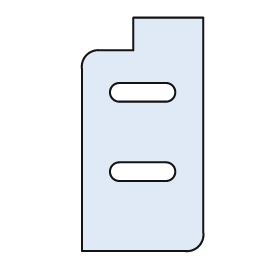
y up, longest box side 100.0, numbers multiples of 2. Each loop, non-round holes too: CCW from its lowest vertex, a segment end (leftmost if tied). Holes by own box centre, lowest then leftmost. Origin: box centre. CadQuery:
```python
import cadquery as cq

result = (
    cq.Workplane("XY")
    .moveTo(-26.0, -50.0)
    .lineTo(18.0, -50.0)
    .threePointArc((24.0, -48.0), (26.0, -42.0))
    .lineTo(26.0, 50.0)
    .lineTo(-4.0, 50.0)
    .lineTo(-4.0, 36.0)
    .lineTo(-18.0, 36.0)
    .threePointArc((-24.0, 34.0), (-26.0, 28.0))
    .close()
    .moveTo(-10.0, -20.0)
    .lineTo(10.0, -20.0)
    .threePointArc((14.0, -16.0), (10.0, -12.0))
    .lineTo(-10.0, -12.0)
    .threePointArc((-14.0, -16.0), (-10.0, -20.0))
    .close()
    .moveTo(-10.0, 14.0)
    .lineTo(10.0, 14.0)
    .threePointArc((14.0, 18.0), (10.0, 22.0))
    .lineTo(-10.0, 22.0)
    .threePointArc((-14.0, 18.0), (-10.0, 14.0))
    .close()
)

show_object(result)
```